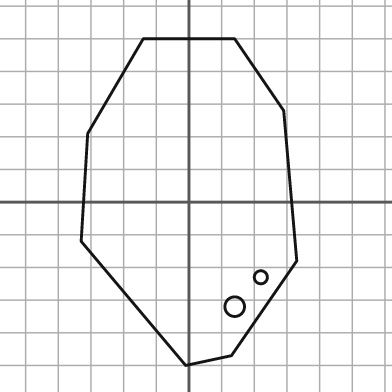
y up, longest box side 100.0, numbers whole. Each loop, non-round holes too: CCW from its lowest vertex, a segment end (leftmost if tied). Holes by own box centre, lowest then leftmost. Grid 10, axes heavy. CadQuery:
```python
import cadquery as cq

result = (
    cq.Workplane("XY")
    .moveTo(-1.0, -50.0)
    .lineTo(13.0, -47.0)
    .lineTo(33.0, -18.0)
    .lineTo(29.0, 28.0)
    .lineTo(14.0, 50.0)
    .lineTo(-14.0, 50.0)
    .lineTo(-31.0, 21.0)
    .lineTo(-33.0, -12.0)
    .close()
    .moveTo(14.0, -32.0)
    .circle(3.0)
    .moveTo(22.0, -23.0)
    .circle(2.0)
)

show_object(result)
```